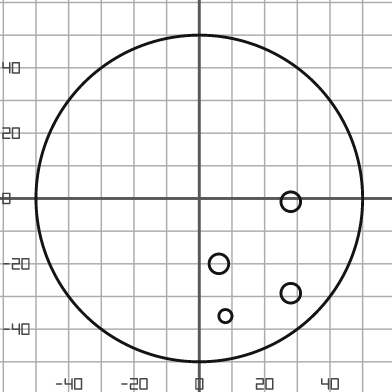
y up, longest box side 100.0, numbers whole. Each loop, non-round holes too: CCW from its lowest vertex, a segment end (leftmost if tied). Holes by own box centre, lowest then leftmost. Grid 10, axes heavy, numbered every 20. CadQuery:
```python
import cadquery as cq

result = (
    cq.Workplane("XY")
    .moveTo(0.0, 0.0)
    .circle(50.0)
    .moveTo(8.0, -36.0)
    .circle(2.0)
    .moveTo(28.0, -29.0)
    .circle(3.0)
    .moveTo(6.0, -20.0)
    .circle(3.0)
    .moveTo(28.0, -1.0)
    .circle(3.0)
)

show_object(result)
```